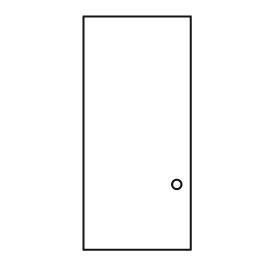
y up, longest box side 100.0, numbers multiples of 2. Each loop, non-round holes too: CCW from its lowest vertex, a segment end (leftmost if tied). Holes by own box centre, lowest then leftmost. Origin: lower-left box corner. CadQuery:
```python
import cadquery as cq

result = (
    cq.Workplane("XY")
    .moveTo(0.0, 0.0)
    .lineTo(46.0, 0.0)
    .lineTo(46.0, 100.0)
    .lineTo(0.0, 100.0)
    .close()
    .moveTo(40.0, 28.0)
    .circle(2.0)
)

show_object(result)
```